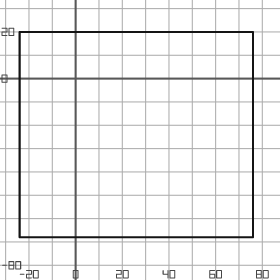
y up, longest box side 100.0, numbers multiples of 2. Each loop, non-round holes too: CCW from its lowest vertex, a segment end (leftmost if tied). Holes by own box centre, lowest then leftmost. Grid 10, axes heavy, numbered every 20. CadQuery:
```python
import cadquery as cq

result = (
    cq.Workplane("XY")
    .moveTo(-24.0, -68.0)
    .lineTo(76.0, -68.0)
    .lineTo(76.0, 20.0)
    .lineTo(-24.0, 20.0)
    .close()
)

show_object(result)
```